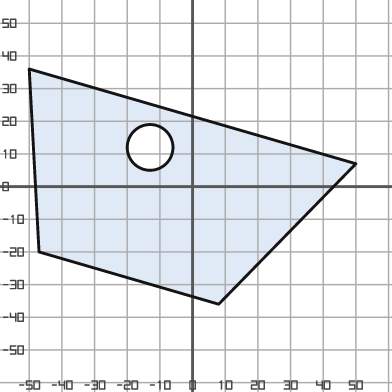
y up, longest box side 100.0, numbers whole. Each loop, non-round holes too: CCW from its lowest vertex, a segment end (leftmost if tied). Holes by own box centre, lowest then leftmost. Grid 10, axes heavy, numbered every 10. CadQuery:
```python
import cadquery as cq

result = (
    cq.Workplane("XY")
    .moveTo(8.0, -36.0)
    .lineTo(50.0, 7.0)
    .lineTo(-50.0, 36.0)
    .lineTo(-47.0, -20.0)
    .close()
    .moveTo(-13.0, 12.0)
    .circle(7.0)
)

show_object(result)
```